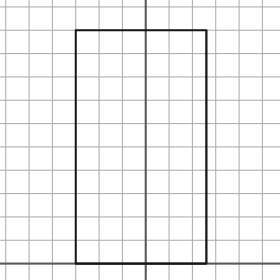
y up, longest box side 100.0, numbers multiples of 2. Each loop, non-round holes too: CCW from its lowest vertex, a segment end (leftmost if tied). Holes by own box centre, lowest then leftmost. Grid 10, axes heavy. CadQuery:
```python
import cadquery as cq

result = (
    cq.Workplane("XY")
    .moveTo(-30.0, 0.0)
    .lineTo(26.0, 0.0)
    .lineTo(26.0, 100.0)
    .lineTo(-30.0, 100.0)
    .close()
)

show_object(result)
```